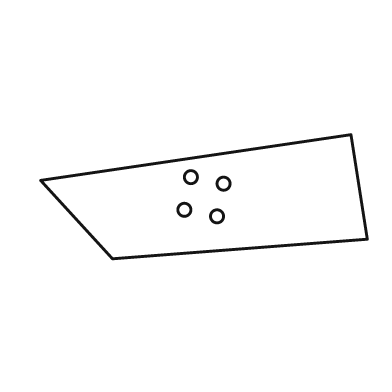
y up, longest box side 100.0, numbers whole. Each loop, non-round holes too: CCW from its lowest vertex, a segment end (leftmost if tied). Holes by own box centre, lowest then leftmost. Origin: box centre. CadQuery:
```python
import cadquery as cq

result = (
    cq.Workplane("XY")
    .moveTo(-28.0, -19.0)
    .lineTo(50.0, -13.0)
    .lineTo(45.0, 19.0)
    .lineTo(-50.0, 5.0)
    .close()
    .moveTo(4.0, -6.0)
    .circle(2.0)
    .moveTo(-6.0, -4.0)
    .circle(2.0)
    .moveTo(6.0, 4.0)
    .circle(2.0)
    .moveTo(-4.0, 6.0)
    .circle(2.0)
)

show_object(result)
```